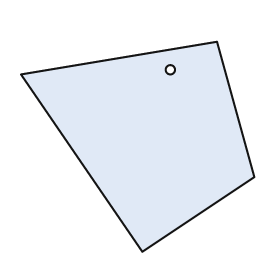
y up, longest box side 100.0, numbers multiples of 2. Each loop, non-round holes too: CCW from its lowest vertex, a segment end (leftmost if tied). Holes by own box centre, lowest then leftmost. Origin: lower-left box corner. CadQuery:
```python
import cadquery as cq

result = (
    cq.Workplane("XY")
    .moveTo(52.0, 0.0)
    .lineTo(100.0, 32.0)
    .lineTo(84.0, 90.0)
    .lineTo(0.0, 76.0)
    .close()
    .moveTo(64.0, 78.0)
    .circle(2.0)
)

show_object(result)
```